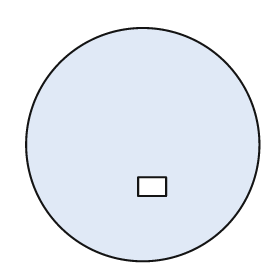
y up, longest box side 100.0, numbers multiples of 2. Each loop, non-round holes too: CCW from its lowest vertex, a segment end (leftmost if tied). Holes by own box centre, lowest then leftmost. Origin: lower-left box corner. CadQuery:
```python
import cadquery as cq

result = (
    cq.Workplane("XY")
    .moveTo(50.0, 50.0)
    .circle(50.0)
    .moveTo(48.0, 28.0)
    .lineTo(60.0, 28.0)
    .lineTo(60.0, 36.0)
    .lineTo(48.0, 36.0)
    .close()
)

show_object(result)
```